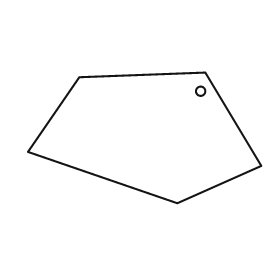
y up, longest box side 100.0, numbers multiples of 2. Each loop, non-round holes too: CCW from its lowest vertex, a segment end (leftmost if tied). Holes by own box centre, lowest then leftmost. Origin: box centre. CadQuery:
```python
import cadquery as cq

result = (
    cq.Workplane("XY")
    .moveTo(14.0, -28.0)
    .lineTo(50.0, -12.0)
    .lineTo(26.0, 28.0)
    .lineTo(-28.0, 26.0)
    .lineTo(-50.0, -6.0)
    .close()
    .moveTo(24.0, 20.0)
    .circle(2.0)
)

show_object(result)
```